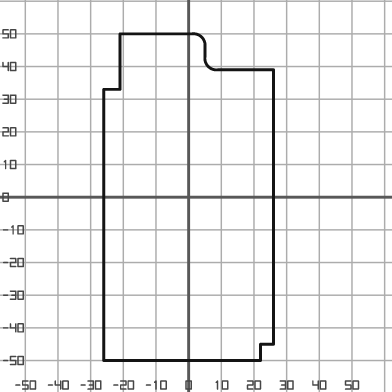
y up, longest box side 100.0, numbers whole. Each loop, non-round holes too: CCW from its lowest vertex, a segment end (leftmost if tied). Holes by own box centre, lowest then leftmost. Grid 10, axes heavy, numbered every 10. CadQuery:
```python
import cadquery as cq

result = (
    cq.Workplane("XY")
    .moveTo(-26.0, -50.0)
    .lineTo(22.0, -50.0)
    .lineTo(22.0, -45.0)
    .lineTo(26.0, -45.0)
    .lineTo(26.0, 39.0)
    .lineTo(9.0, 39.0)
    .threePointArc((6.0, 40.0), (5.0, 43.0))
    .lineTo(5.0, 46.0)
    .threePointArc((4.0, 49.0), (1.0, 50.0))
    .lineTo(-21.0, 50.0)
    .lineTo(-21.0, 33.0)
    .lineTo(-26.0, 33.0)
    .close()
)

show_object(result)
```